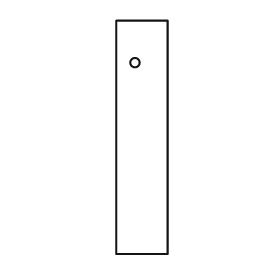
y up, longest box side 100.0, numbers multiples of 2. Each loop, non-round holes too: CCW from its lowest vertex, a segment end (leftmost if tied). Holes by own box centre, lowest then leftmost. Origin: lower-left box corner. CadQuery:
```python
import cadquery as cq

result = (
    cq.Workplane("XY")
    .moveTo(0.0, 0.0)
    .lineTo(22.0, 0.0)
    .lineTo(22.0, 100.0)
    .lineTo(0.0, 100.0)
    .close()
    .moveTo(8.0, 82.0)
    .circle(2.0)
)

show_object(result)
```